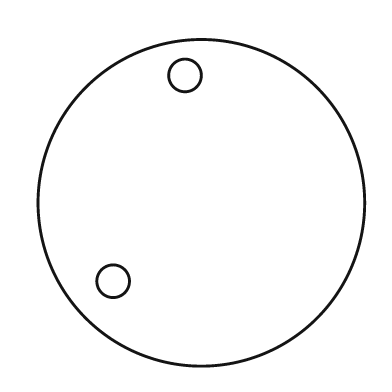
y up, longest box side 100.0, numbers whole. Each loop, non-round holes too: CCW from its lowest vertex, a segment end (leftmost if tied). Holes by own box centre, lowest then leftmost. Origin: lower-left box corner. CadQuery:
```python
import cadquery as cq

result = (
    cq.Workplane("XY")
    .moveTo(50.0, 50.0)
    .circle(50.0)
    .moveTo(23.0, 26.0)
    .circle(5.0)
    .moveTo(45.0, 89.0)
    .circle(5.0)
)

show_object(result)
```